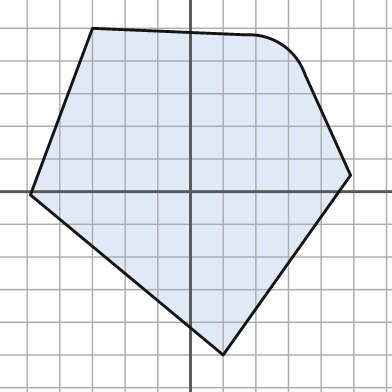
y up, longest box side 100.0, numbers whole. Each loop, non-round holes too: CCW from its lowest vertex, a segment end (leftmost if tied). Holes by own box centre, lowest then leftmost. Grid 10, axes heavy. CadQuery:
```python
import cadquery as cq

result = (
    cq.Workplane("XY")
    .moveTo(10.0, -50.0)
    .lineTo(49.0, 5.0)
    .lineTo(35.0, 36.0)
    .threePointArc((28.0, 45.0), (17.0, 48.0))
    .lineTo(-30.0, 50.0)
    .lineTo(-49.0, -1.0)
    .close()
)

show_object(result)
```